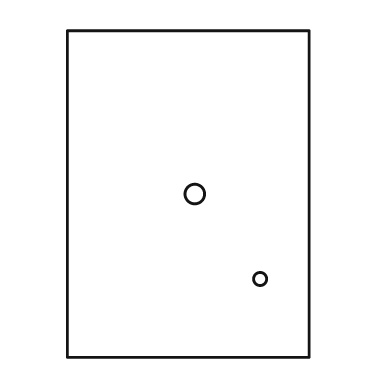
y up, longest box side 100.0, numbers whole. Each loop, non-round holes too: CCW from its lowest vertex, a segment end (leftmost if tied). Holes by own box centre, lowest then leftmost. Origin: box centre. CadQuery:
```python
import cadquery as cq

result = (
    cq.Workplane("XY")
    .moveTo(-37.0, -50.0)
    .lineTo(37.0, -50.0)
    .lineTo(37.0, 50.0)
    .lineTo(-37.0, 50.0)
    .close()
    .moveTo(22.0, -26.0)
    .circle(2.0)
    .moveTo(2.0, 0.0)
    .circle(3.0)
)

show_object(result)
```